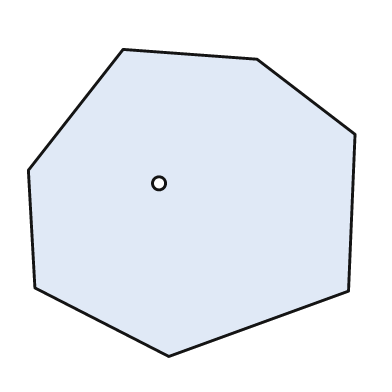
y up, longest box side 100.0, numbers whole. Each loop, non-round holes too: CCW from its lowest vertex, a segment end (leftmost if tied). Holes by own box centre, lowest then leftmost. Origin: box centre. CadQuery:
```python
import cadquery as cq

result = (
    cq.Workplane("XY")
    .moveTo(-7.0, -47.0)
    .lineTo(48.0, -27.0)
    .lineTo(50.0, 21.0)
    .lineTo(20.0, 44.0)
    .lineTo(-21.0, 47.0)
    .lineTo(-50.0, 10.0)
    .lineTo(-48.0, -26.0)
    .close()
    .moveTo(-10.0, 6.0)
    .circle(2.0)
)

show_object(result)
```